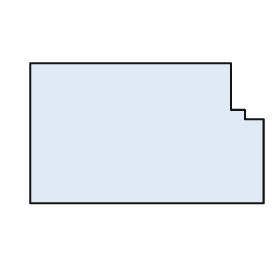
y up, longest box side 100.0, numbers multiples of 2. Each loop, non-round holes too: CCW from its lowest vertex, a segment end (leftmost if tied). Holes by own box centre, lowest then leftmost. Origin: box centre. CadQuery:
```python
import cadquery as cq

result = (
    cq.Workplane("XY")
    .moveTo(-50.0, -30.0)
    .lineTo(50.0, -30.0)
    .lineTo(50.0, 6.0)
    .lineTo(42.0, 6.0)
    .lineTo(42.0, 10.0)
    .lineTo(36.0, 10.0)
    .lineTo(36.0, 30.0)
    .lineTo(-50.0, 30.0)
    .close()
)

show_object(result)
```